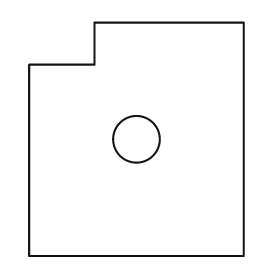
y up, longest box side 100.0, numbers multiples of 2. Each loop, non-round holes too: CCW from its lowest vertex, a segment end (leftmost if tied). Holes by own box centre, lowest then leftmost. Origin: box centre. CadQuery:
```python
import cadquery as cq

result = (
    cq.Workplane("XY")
    .moveTo(-46.0, -50.0)
    .lineTo(46.0, -50.0)
    .lineTo(46.0, 50.0)
    .lineTo(-18.0, 50.0)
    .lineTo(-18.0, 32.0)
    .lineTo(-46.0, 32.0)
    .close()
    .moveTo(0.0, 0.0)
    .circle(10.0)
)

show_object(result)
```